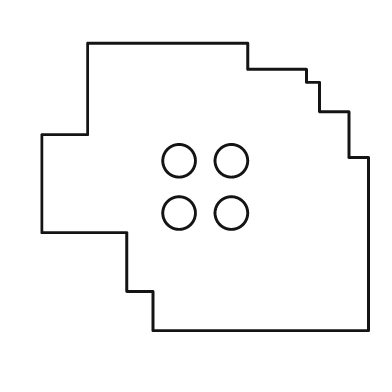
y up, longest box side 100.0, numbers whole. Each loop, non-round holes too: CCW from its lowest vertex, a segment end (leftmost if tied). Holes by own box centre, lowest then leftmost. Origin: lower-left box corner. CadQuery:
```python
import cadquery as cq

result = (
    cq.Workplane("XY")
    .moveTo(34.0, 0.0)
    .lineTo(100.0, 0.0)
    .lineTo(100.0, 53.0)
    .lineTo(94.0, 53.0)
    .lineTo(94.0, 67.0)
    .lineTo(85.0, 67.0)
    .lineTo(85.0, 76.0)
    .lineTo(81.0, 76.0)
    .lineTo(81.0, 80.0)
    .lineTo(63.0, 80.0)
    .lineTo(63.0, 88.0)
    .lineTo(14.0, 88.0)
    .lineTo(14.0, 60.0)
    .lineTo(0.0, 60.0)
    .lineTo(0.0, 30.0)
    .lineTo(26.0, 30.0)
    .lineTo(26.0, 12.0)
    .lineTo(34.0, 12.0)
    .close()
    .moveTo(42.0, 36.0)
    .circle(5.0)
    .moveTo(58.0, 36.0)
    .circle(5.0)
    .moveTo(42.0, 52.0)
    .circle(5.0)
    .moveTo(58.0, 52.0)
    .circle(5.0)
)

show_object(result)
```